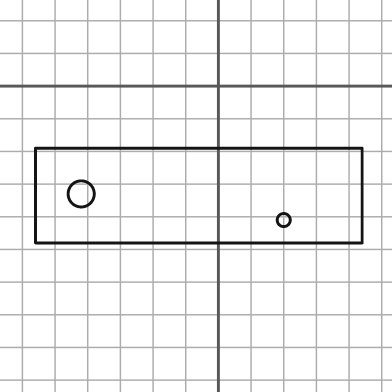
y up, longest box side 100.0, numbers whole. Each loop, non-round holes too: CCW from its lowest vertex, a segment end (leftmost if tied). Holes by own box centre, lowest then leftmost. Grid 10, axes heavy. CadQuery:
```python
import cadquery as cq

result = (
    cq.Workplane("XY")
    .moveTo(-56.0, -48.0)
    .lineTo(44.0, -48.0)
    .lineTo(44.0, -19.0)
    .lineTo(-56.0, -19.0)
    .close()
    .moveTo(20.0, -41.0)
    .circle(2.0)
    .moveTo(-42.0, -33.0)
    .circle(4.0)
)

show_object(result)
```